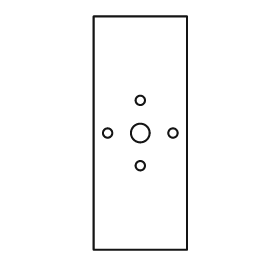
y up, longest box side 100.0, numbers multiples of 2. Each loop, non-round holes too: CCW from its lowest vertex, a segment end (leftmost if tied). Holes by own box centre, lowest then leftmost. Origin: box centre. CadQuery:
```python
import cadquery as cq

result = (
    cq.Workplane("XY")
    .moveTo(-20.0, -50.0)
    .lineTo(20.0, -50.0)
    .lineTo(20.0, 50.0)
    .lineTo(-20.0, 50.0)
    .close()
    .moveTo(0.0, -14.0)
    .circle(2.0)
    .moveTo(-14.0, 0.0)
    .circle(2.0)
    .moveTo(0.0, 0.0)
    .circle(4.0)
    .moveTo(14.0, 0.0)
    .circle(2.0)
    .moveTo(0.0, 14.0)
    .circle(2.0)
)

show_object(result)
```